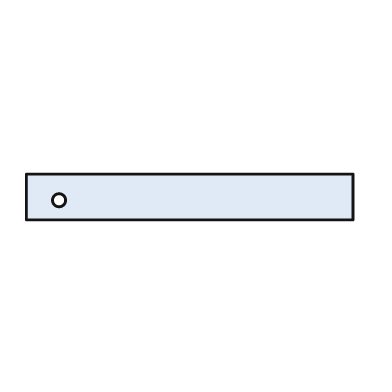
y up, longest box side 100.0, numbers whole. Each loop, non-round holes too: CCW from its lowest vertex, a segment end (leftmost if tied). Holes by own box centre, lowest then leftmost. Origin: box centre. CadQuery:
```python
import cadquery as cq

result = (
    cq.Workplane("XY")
    .moveTo(-50.0, -7.0)
    .lineTo(50.0, -7.0)
    .lineTo(50.0, 7.0)
    .lineTo(-50.0, 7.0)
    .close()
    .moveTo(-40.0, -1.0)
    .circle(2.0)
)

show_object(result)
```